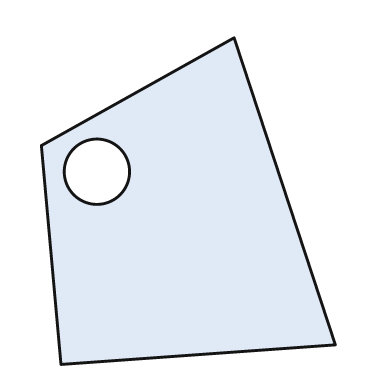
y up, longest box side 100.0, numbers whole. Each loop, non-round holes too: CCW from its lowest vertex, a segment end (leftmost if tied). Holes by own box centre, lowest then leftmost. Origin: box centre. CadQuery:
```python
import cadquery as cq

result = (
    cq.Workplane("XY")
    .moveTo(-39.0, -50.0)
    .lineTo(45.0, -44.0)
    .lineTo(14.0, 50.0)
    .lineTo(-45.0, 17.0)
    .close()
    .moveTo(-28.0, 9.0)
    .circle(10.0)
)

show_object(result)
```